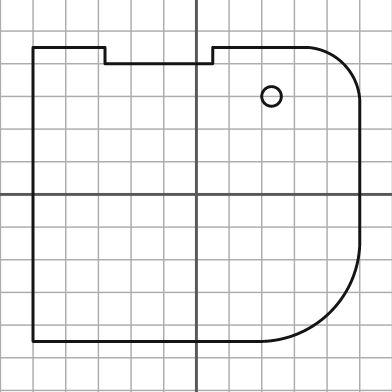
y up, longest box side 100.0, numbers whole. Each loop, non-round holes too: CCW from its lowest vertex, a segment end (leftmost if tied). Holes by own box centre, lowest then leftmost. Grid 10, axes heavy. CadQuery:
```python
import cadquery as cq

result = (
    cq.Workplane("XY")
    .moveTo(-50.0, -45.0)
    .lineTo(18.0, -45.0)
    .threePointArc((41.0, -36.0), (50.0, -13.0))
    .lineTo(50.0, 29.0)
    .threePointArc((45.0, 40.0), (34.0, 45.0))
    .lineTo(5.0, 45.0)
    .lineTo(5.0, 40.0)
    .lineTo(-28.0, 40.0)
    .lineTo(-28.0, 45.0)
    .lineTo(-50.0, 45.0)
    .close()
    .moveTo(23.0, 30.0)
    .circle(3.0)
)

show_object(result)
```